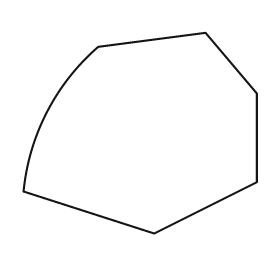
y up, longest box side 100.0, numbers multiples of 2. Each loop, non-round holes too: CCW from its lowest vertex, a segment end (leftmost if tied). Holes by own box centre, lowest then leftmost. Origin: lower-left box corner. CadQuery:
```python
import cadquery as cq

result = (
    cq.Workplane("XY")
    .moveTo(56.0, 0.0)
    .lineTo(100.0, 22.0)
    .lineTo(100.0, 60.0)
    .lineTo(78.0, 86.0)
    .lineTo(32.0, 80.0)
    .threePointArc((10.0, 52.0), (0.0, 18.0))
    .close()
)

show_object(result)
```